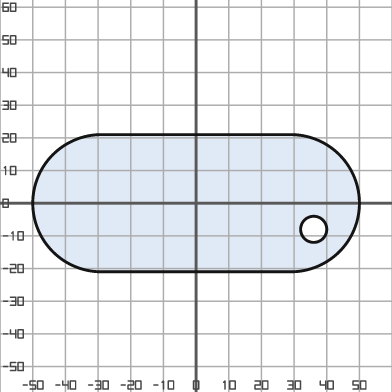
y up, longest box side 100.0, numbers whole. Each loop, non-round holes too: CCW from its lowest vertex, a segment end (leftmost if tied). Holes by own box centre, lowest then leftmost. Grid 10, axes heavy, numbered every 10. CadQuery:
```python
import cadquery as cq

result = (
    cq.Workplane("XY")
    .moveTo(-29.0, -21.0)
    .lineTo(29.0, -21.0)
    .threePointArc((50.0, 0.0), (29.0, 21.0))
    .lineTo(-29.0, 21.0)
    .threePointArc((-50.0, 0.0), (-29.0, -21.0))
    .close()
    .moveTo(36.0, -8.0)
    .circle(4.0)
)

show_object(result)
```